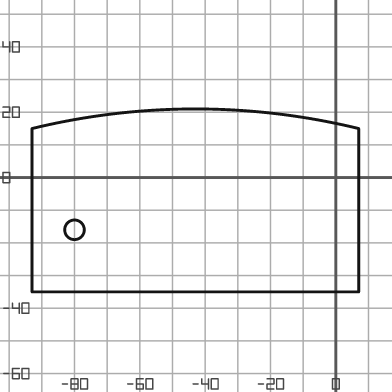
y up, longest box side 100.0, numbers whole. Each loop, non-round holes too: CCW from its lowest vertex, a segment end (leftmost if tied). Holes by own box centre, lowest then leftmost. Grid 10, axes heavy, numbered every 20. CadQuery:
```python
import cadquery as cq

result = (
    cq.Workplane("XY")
    .moveTo(-93.0, -35.0)
    .lineTo(7.0, -35.0)
    .lineTo(7.0, 15.0)
    .threePointArc((-43.0, 21.0), (-93.0, 15.0))
    .close()
    .moveTo(-80.0, -16.0)
    .circle(3.0)
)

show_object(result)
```